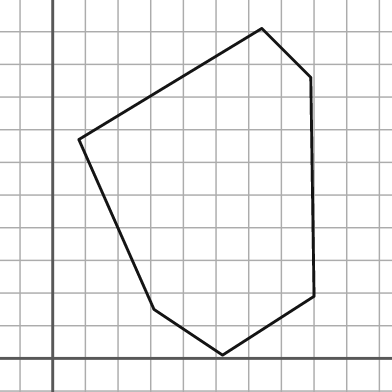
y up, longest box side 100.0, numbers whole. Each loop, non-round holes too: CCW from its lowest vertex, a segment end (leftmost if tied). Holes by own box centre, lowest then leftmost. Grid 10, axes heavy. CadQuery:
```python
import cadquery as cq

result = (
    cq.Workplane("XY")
    .moveTo(52.0, 1.0)
    .lineTo(80.0, 19.0)
    .lineTo(79.0, 86.0)
    .lineTo(64.0, 101.0)
    .lineTo(8.0, 67.0)
    .lineTo(31.0, 15.0)
    .close()
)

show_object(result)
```